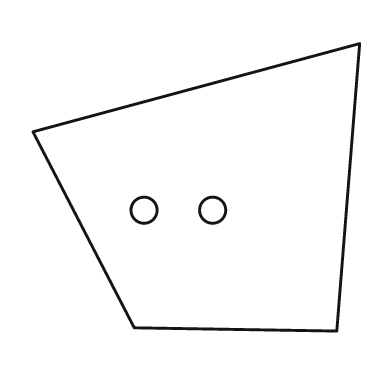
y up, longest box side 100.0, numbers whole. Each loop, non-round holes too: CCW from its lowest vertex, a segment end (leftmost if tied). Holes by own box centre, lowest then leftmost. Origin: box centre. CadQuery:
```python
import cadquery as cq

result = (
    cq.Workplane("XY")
    .moveTo(43.0, -44.0)
    .lineTo(50.0, 44.0)
    .lineTo(-50.0, 17.0)
    .lineTo(-19.0, -43.0)
    .close()
    .moveTo(-16.0, -7.0)
    .circle(4.0)
    .moveTo(5.0, -7.0)
    .circle(4.0)
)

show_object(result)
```